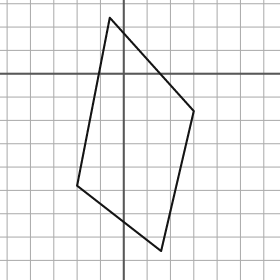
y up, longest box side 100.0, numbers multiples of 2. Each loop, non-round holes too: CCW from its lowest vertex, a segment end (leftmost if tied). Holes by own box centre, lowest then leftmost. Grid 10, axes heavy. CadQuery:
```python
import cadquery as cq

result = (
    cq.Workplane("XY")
    .moveTo(16.0, -76.0)
    .lineTo(30.0, -16.0)
    .lineTo(-6.0, 24.0)
    .lineTo(-20.0, -48.0)
    .close()
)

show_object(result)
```